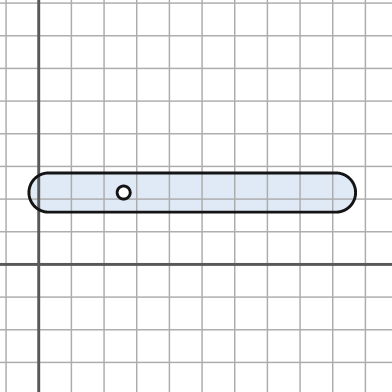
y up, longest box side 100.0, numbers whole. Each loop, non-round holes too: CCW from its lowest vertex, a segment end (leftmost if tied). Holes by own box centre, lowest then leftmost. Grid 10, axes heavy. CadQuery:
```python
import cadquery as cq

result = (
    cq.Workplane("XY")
    .moveTo(3.0, 16.0)
    .lineTo(91.0, 16.0)
    .threePointArc((97.0, 22.0), (91.0, 28.0))
    .lineTo(3.0, 28.0)
    .threePointArc((-3.0, 22.0), (3.0, 16.0))
    .close()
    .moveTo(26.0, 22.0)
    .circle(2.0)
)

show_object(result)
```